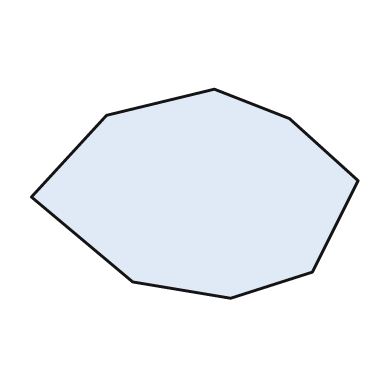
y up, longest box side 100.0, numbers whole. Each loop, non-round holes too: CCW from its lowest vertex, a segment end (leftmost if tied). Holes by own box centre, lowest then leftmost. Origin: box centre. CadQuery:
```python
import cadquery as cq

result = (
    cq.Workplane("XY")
    .moveTo(11.0, -32.0)
    .lineTo(36.0, -24.0)
    .lineTo(50.0, 4.0)
    .lineTo(29.0, 23.0)
    .lineTo(6.0, 32.0)
    .lineTo(-27.0, 24.0)
    .lineTo(-50.0, -1.0)
    .lineTo(-19.0, -27.0)
    .close()
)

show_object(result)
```